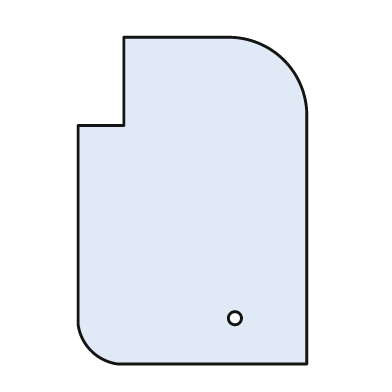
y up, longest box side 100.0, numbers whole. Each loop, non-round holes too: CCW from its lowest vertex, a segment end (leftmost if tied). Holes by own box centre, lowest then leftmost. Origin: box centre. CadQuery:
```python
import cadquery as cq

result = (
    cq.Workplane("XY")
    .moveTo(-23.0, -50.0)
    .lineTo(35.0, -50.0)
    .lineTo(35.0, 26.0)
    .threePointArc((28.0, 43.0), (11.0, 50.0))
    .lineTo(-21.0, 50.0)
    .lineTo(-21.0, 23.0)
    .lineTo(-35.0, 23.0)
    .lineTo(-35.0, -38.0)
    .threePointArc((-31.0, -46.0), (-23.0, -50.0))
    .close()
    .moveTo(13.0, -36.0)
    .circle(2.0)
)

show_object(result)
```